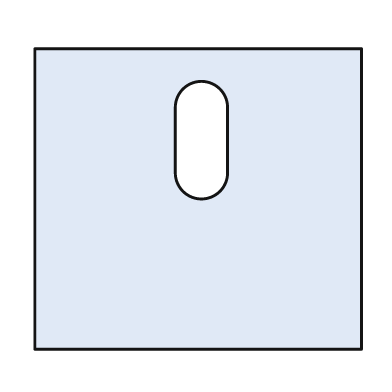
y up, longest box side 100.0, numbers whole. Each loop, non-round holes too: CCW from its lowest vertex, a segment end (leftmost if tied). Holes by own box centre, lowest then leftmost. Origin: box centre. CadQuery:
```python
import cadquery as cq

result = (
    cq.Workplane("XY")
    .moveTo(-50.0, -46.0)
    .lineTo(50.0, -46.0)
    .lineTo(50.0, 46.0)
    .lineTo(-50.0, 46.0)
    .close()
    .moveTo(-7.0, 8.0)
    .threePointArc((1.0, 0.0), (9.0, 8.0))
    .lineTo(9.0, 28.0)
    .threePointArc((1.0, 36.0), (-7.0, 28.0))
    .close()
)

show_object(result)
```